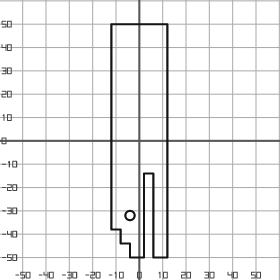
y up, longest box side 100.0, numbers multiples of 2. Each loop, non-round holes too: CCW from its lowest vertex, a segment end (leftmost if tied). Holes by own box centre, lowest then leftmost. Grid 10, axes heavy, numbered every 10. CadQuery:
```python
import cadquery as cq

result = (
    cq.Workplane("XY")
    .moveTo(-4.0, -50.0)
    .lineTo(2.0, -50.0)
    .lineTo(2.0, -14.0)
    .lineTo(6.0, -14.0)
    .lineTo(6.0, -50.0)
    .lineTo(12.0, -50.0)
    .lineTo(12.0, 50.0)
    .lineTo(-12.0, 50.0)
    .lineTo(-12.0, -38.0)
    .lineTo(-8.0, -38.0)
    .lineTo(-8.0, -44.0)
    .lineTo(-4.0, -44.0)
    .close()
    .moveTo(-4.0, -32.0)
    .circle(2.0)
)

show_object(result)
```